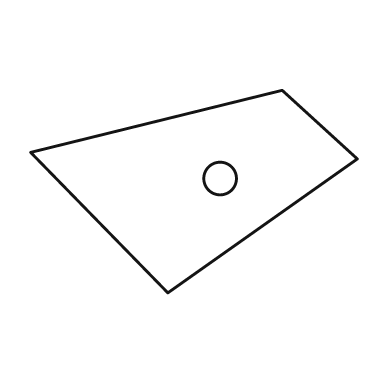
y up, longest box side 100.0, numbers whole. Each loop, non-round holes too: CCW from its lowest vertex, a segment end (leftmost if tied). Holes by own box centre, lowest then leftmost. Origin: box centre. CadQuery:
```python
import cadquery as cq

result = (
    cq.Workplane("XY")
    .moveTo(-8.0, -31.0)
    .lineTo(50.0, 10.0)
    .lineTo(27.0, 31.0)
    .lineTo(-50.0, 12.0)
    .close()
    .moveTo(8.0, 4.0)
    .circle(5.0)
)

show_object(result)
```